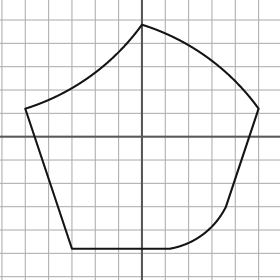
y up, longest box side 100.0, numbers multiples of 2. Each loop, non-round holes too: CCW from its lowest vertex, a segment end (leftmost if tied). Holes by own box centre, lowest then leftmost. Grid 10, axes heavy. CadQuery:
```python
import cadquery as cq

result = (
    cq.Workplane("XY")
    .moveTo(-30.0, -48.0)
    .lineTo(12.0, -48.0)
    .threePointArc((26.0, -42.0), (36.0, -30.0))
    .lineTo(50.0, 12.0)
    .threePointArc((28.0, 34.0), (0.0, 48.0))
    .threePointArc((-22.0, 26.0), (-50.0, 12.0))
    .close()
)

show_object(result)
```